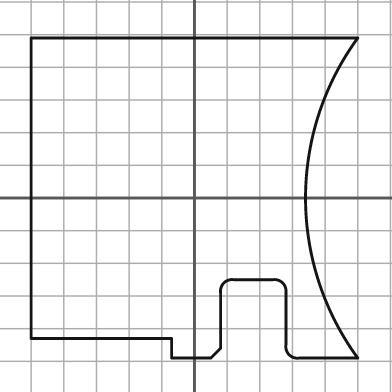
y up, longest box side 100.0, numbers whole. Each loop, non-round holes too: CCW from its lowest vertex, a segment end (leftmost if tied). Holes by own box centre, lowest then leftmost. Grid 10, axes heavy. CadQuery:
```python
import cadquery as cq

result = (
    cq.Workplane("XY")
    .moveTo(-7.0, -49.0)
    .lineTo(5.0, -49.0)
    .lineTo(8.0, -46.0)
    .lineTo(8.0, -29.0)
    .threePointArc((9.0, -26.0), (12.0, -25.0))
    .lineTo(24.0, -25.0)
    .threePointArc((27.0, -26.0), (28.0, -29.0))
    .lineTo(28.0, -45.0)
    .threePointArc((29.0, -48.0), (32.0, -49.0))
    .lineTo(50.0, -49.0)
    .threePointArc((34.0, 0.0), (50.0, 49.0))
    .lineTo(-50.0, 49.0)
    .lineTo(-50.0, -43.0)
    .lineTo(-7.0, -43.0)
    .close()
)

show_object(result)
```